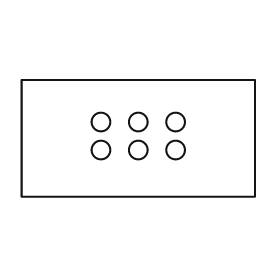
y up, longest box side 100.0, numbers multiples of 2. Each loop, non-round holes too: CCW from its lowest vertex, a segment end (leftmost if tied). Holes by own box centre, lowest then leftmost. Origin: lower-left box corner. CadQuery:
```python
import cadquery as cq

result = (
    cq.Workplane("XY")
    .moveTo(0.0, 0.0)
    .lineTo(100.0, 0.0)
    .lineTo(100.0, 50.0)
    .lineTo(0.0, 50.0)
    .close()
    .moveTo(34.0, 20.0)
    .circle(4.0)
    .moveTo(50.0, 20.0)
    .circle(4.0)
    .moveTo(66.0, 20.0)
    .circle(4.0)
    .moveTo(34.0, 32.0)
    .circle(4.0)
    .moveTo(50.0, 32.0)
    .circle(4.0)
    .moveTo(66.0, 32.0)
    .circle(4.0)
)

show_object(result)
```